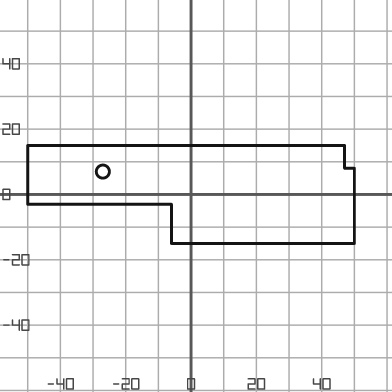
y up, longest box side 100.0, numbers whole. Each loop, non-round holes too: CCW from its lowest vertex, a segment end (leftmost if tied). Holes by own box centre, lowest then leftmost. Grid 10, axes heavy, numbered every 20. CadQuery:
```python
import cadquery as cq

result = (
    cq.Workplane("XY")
    .moveTo(-6.0, -15.0)
    .lineTo(50.0, -15.0)
    .lineTo(50.0, 8.0)
    .lineTo(47.0, 8.0)
    .lineTo(47.0, 15.0)
    .lineTo(-50.0, 15.0)
    .lineTo(-50.0, -3.0)
    .lineTo(-6.0, -3.0)
    .close()
    .moveTo(-27.0, 7.0)
    .circle(2.0)
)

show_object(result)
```